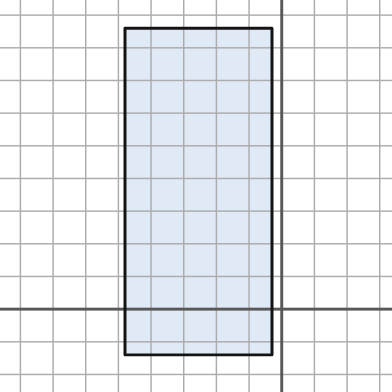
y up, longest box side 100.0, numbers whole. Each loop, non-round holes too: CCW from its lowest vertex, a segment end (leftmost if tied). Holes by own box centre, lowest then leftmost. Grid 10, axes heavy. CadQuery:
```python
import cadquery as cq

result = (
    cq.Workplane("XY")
    .moveTo(-48.0, -14.0)
    .lineTo(-3.0, -14.0)
    .lineTo(-3.0, 86.0)
    .lineTo(-48.0, 86.0)
    .close()
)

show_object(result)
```